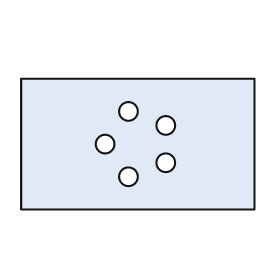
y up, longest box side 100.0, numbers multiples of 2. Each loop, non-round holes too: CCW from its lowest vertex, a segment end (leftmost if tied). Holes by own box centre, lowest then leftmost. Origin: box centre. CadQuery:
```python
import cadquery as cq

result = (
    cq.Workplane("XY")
    .moveTo(-50.0, -28.0)
    .lineTo(50.0, -28.0)
    .lineTo(50.0, 28.0)
    .lineTo(-50.0, 28.0)
    .close()
    .moveTo(-4.0, -14.0)
    .circle(4.0)
    .moveTo(12.0, -8.0)
    .circle(4.0)
    .moveTo(-14.0, 0.0)
    .circle(4.0)
    .moveTo(12.0, 8.0)
    .circle(4.0)
    .moveTo(-4.0, 14.0)
    .circle(4.0)
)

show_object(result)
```